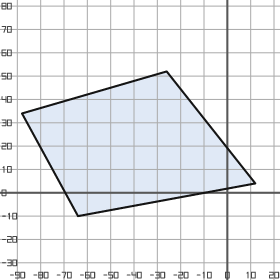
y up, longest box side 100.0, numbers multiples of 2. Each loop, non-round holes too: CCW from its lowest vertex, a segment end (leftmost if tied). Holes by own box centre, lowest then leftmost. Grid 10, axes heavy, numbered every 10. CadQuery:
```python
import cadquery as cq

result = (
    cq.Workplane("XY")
    .moveTo(-64.0, -10.0)
    .lineTo(12.0, 4.0)
    .lineTo(-26.0, 52.0)
    .lineTo(-88.0, 34.0)
    .close()
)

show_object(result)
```